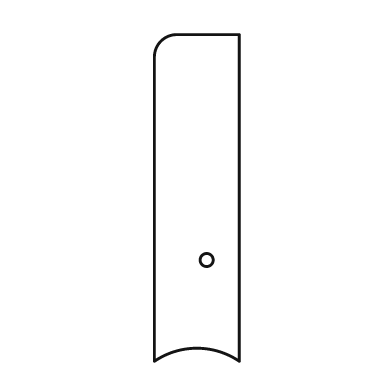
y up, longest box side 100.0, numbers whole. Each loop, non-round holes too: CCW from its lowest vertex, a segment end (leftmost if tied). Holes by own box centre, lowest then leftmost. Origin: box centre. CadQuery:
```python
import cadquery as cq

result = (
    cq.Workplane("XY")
    .moveTo(-13.0, -50.0)
    .threePointArc((0.0, -46.0), (13.0, -50.0))
    .lineTo(13.0, 50.0)
    .lineTo(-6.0, 50.0)
    .threePointArc((-11.0, 48.0), (-13.0, 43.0))
    .close()
    .moveTo(3.0, -19.0)
    .circle(2.0)
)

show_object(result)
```